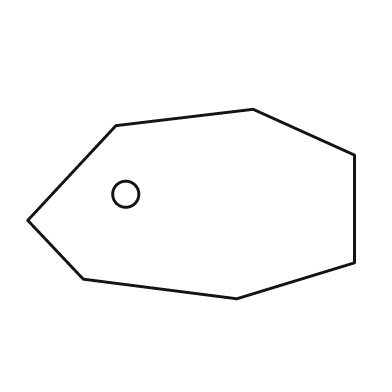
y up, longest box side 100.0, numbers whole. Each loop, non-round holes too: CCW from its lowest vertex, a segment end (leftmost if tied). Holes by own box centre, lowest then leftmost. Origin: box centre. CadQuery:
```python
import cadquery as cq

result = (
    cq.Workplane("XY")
    .moveTo(14.0, -29.0)
    .lineTo(50.0, -18.0)
    .lineTo(50.0, 15.0)
    .lineTo(19.0, 29.0)
    .lineTo(-23.0, 24.0)
    .lineTo(-50.0, -5.0)
    .lineTo(-33.0, -23.0)
    .close()
    .moveTo(-20.0, 3.0)
    .circle(4.0)
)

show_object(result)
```